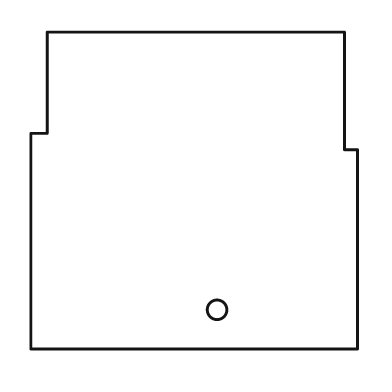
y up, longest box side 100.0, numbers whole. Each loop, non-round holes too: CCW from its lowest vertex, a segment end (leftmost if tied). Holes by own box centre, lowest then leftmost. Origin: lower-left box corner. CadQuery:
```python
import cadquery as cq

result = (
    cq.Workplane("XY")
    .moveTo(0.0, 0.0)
    .lineTo(100.0, 0.0)
    .lineTo(100.0, 61.0)
    .lineTo(96.0, 61.0)
    .lineTo(96.0, 97.0)
    .lineTo(5.0, 97.0)
    .lineTo(5.0, 66.0)
    .lineTo(0.0, 66.0)
    .close()
    .moveTo(57.0, 12.0)
    .circle(3.0)
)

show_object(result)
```